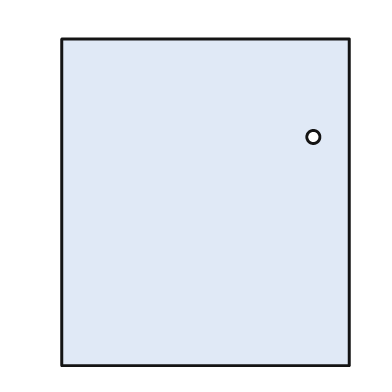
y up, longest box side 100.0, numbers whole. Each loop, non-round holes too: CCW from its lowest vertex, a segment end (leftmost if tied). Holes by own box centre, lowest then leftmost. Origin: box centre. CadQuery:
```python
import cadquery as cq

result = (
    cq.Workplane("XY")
    .moveTo(-44.0, -50.0)
    .lineTo(44.0, -50.0)
    .lineTo(44.0, 50.0)
    .lineTo(-44.0, 50.0)
    .close()
    .moveTo(33.0, 20.0)
    .circle(2.0)
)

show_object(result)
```